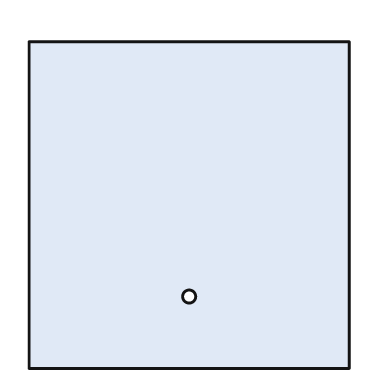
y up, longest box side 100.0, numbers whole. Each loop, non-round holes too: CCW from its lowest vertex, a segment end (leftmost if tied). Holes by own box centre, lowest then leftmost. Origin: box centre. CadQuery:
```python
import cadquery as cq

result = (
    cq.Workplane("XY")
    .moveTo(-49.0, -50.0)
    .lineTo(49.0, -50.0)
    .lineTo(49.0, 50.0)
    .lineTo(-49.0, 50.0)
    .close()
    .moveTo(0.0, -28.0)
    .circle(2.0)
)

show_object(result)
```